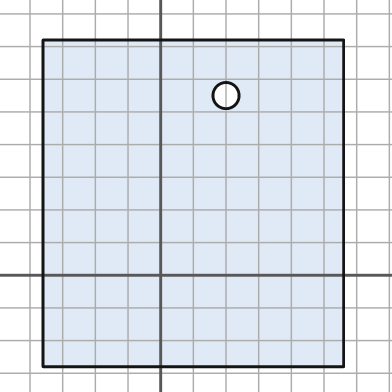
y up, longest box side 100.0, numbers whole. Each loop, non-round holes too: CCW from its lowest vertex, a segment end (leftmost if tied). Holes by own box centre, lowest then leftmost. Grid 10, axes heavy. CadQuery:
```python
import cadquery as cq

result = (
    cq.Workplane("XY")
    .moveTo(-36.0, -28.0)
    .lineTo(56.0, -28.0)
    .lineTo(56.0, 72.0)
    .lineTo(-36.0, 72.0)
    .close()
    .moveTo(20.0, 55.0)
    .circle(4.0)
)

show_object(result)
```